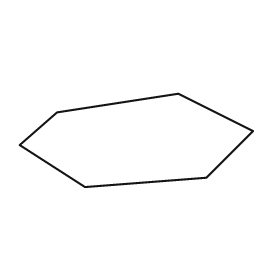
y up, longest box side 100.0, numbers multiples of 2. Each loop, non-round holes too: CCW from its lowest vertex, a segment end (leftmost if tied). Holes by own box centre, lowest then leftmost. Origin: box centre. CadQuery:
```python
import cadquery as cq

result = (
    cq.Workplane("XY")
    .moveTo(-22.0, -20.0)
    .lineTo(30.0, -16.0)
    .lineTo(50.0, 4.0)
    .lineTo(18.0, 20.0)
    .lineTo(-34.0, 12.0)
    .lineTo(-50.0, -2.0)
    .close()
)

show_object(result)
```